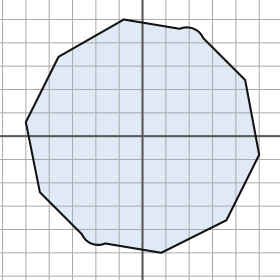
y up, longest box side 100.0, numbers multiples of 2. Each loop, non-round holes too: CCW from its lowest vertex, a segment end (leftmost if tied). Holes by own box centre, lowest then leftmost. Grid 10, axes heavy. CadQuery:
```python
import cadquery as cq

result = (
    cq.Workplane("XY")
    .moveTo(8.0, -50.0)
    .lineTo(36.0, -36.0)
    .lineTo(50.0, -8.0)
    .lineTo(44.0, 24.0)
    .lineTo(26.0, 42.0)
    .threePointArc((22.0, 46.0), (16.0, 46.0))
    .lineTo(-8.0, 50.0)
    .lineTo(-36.0, 34.0)
    .lineTo(-50.0, 6.0)
    .lineTo(-44.0, -24.0)
    .lineTo(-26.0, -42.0)
    .threePointArc((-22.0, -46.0), (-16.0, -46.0))
    .close()
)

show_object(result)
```